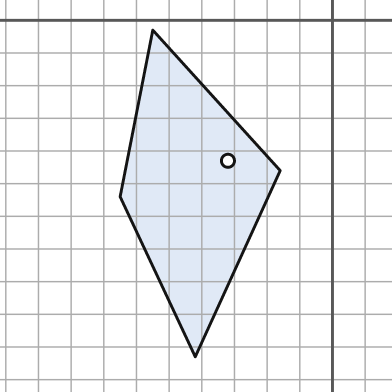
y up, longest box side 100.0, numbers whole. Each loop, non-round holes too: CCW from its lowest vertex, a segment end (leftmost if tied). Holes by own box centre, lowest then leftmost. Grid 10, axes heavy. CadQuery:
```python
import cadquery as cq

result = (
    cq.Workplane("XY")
    .moveTo(-42.0, -103.0)
    .lineTo(-16.0, -46.0)
    .lineTo(-55.0, -3.0)
    .lineTo(-65.0, -54.0)
    .close()
    .moveTo(-32.0, -43.0)
    .circle(2.0)
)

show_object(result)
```